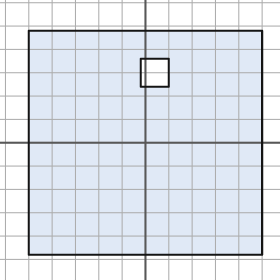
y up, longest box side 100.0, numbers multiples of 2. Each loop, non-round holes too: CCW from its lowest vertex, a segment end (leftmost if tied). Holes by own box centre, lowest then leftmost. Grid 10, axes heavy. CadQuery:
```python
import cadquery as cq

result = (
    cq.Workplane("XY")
    .moveTo(-50.0, -48.0)
    .lineTo(50.0, -48.0)
    .lineTo(50.0, 48.0)
    .lineTo(-50.0, 48.0)
    .close()
    .moveTo(-2.0, 24.0)
    .lineTo(10.0, 24.0)
    .lineTo(10.0, 36.0)
    .lineTo(-2.0, 36.0)
    .close()
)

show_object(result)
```